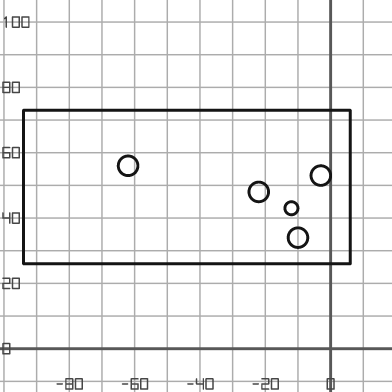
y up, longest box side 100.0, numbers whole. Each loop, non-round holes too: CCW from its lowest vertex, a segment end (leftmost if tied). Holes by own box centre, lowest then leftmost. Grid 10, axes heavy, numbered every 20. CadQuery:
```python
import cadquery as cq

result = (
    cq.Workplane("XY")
    .moveTo(-94.0, 26.0)
    .lineTo(6.0, 26.0)
    .lineTo(6.0, 73.0)
    .lineTo(-94.0, 73.0)
    .close()
    .moveTo(-10.0, 34.0)
    .circle(3.0)
    .moveTo(-12.0, 43.0)
    .circle(2.0)
    .moveTo(-22.0, 48.0)
    .circle(3.0)
    .moveTo(-3.0, 53.0)
    .circle(3.0)
    .moveTo(-62.0, 56.0)
    .circle(3.0)
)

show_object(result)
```